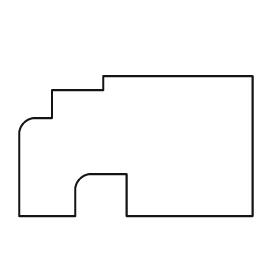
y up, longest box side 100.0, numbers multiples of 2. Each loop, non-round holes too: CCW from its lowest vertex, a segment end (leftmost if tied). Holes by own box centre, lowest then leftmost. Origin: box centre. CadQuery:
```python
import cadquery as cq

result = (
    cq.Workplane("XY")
    .moveTo(-50.0, -30.0)
    .lineTo(-26.0, -30.0)
    .lineTo(-26.0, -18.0)
    .threePointArc((-24.0, -14.0), (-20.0, -12.0))
    .lineTo(-4.0, -12.0)
    .lineTo(-4.0, -30.0)
    .lineTo(50.0, -30.0)
    .lineTo(50.0, 30.0)
    .lineTo(-14.0, 30.0)
    .lineTo(-14.0, 24.0)
    .lineTo(-36.0, 24.0)
    .lineTo(-36.0, 12.0)
    .lineTo(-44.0, 12.0)
    .threePointArc((-48.0, 10.0), (-50.0, 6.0))
    .close()
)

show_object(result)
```